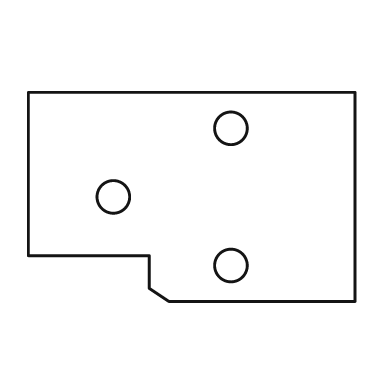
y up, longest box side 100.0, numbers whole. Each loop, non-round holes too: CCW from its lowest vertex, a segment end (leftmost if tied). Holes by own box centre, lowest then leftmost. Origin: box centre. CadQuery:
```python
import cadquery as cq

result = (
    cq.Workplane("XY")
    .moveTo(-7.0, -32.0)
    .lineTo(50.0, -32.0)
    .lineTo(50.0, 32.0)
    .lineTo(-50.0, 32.0)
    .lineTo(-50.0, -18.0)
    .lineTo(-13.0, -18.0)
    .lineTo(-13.0, -28.0)
    .close()
    .moveTo(12.0, -21.0)
    .circle(5.0)
    .moveTo(-24.0, 0.0)
    .circle(5.0)
    .moveTo(12.0, 21.0)
    .circle(5.0)
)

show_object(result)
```